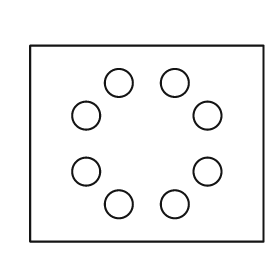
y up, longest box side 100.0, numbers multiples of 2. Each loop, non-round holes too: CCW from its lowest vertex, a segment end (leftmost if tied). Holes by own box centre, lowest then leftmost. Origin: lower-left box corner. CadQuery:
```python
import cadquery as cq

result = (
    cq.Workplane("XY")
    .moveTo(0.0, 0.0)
    .lineTo(100.0, 0.0)
    .lineTo(100.0, 84.0)
    .lineTo(0.0, 84.0)
    .close()
    .moveTo(38.0, 16.0)
    .circle(6.0)
    .moveTo(62.0, 16.0)
    .circle(6.0)
    .moveTo(24.0, 30.0)
    .circle(6.0)
    .moveTo(76.0, 30.0)
    .circle(6.0)
    .moveTo(24.0, 54.0)
    .circle(6.0)
    .moveTo(76.0, 54.0)
    .circle(6.0)
    .moveTo(38.0, 68.0)
    .circle(6.0)
    .moveTo(62.0, 68.0)
    .circle(6.0)
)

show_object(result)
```